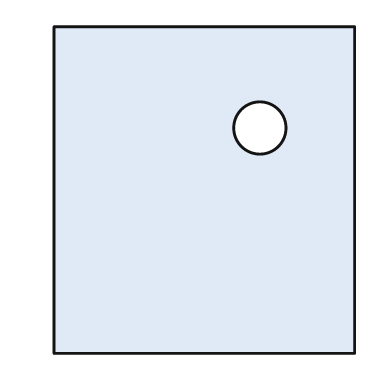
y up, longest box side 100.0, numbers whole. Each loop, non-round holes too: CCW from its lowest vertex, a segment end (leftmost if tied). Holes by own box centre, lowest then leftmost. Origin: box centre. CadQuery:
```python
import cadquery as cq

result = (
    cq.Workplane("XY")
    .moveTo(-46.0, -50.0)
    .lineTo(46.0, -50.0)
    .lineTo(46.0, 50.0)
    .lineTo(-46.0, 50.0)
    .close()
    .moveTo(17.0, 19.0)
    .circle(8.0)
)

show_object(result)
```